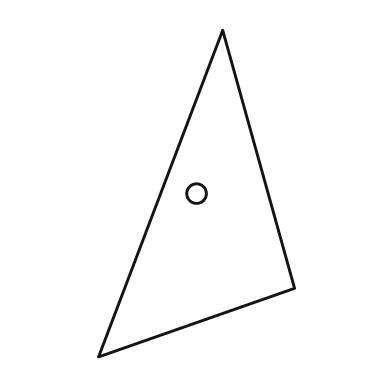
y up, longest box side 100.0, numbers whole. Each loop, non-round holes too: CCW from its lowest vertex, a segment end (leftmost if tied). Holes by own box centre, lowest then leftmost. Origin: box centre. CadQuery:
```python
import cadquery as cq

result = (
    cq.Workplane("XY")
    .moveTo(-30.0, -50.0)
    .lineTo(30.0, -29.0)
    .lineTo(8.0, 50.0)
    .close()
    .moveTo(0.0, 0.0)
    .circle(3.0)
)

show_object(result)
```